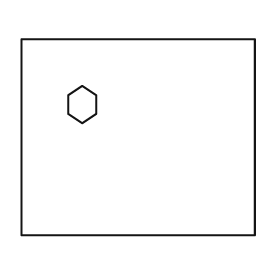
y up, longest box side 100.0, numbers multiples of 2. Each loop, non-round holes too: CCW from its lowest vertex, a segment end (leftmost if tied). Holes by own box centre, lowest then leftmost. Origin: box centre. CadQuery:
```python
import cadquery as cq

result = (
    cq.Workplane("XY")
    .moveTo(-50.0, -42.0)
    .lineTo(50.0, -42.0)
    .lineTo(50.0, 42.0)
    .lineTo(-50.0, 42.0)
    .close()
    .moveTo(-24.0, 6.0)
    .lineTo(-18.0, 10.0)
    .lineTo(-18.0, 18.0)
    .lineTo(-24.0, 22.0)
    .lineTo(-30.0, 18.0)
    .lineTo(-30.0, 10.0)
    .close()
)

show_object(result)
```